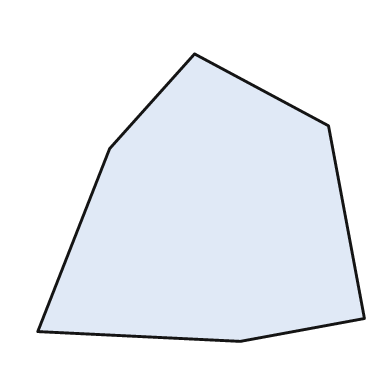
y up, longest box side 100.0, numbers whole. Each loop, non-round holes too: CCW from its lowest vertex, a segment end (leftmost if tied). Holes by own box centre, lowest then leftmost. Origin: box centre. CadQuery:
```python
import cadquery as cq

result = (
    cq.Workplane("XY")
    .moveTo(12.0, -44.0)
    .lineTo(50.0, -37.0)
    .lineTo(39.0, 22.0)
    .lineTo(-2.0, 44.0)
    .lineTo(-28.0, 15.0)
    .lineTo(-50.0, -41.0)
    .close()
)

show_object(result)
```